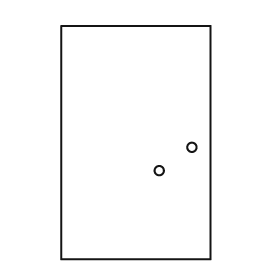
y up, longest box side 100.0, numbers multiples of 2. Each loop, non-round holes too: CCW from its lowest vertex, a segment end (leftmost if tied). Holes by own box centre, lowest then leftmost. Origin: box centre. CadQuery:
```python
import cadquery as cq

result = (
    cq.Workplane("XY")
    .moveTo(-32.0, -50.0)
    .lineTo(32.0, -50.0)
    .lineTo(32.0, 50.0)
    .lineTo(-32.0, 50.0)
    .close()
    .moveTo(10.0, -12.0)
    .circle(2.0)
    .moveTo(24.0, -2.0)
    .circle(2.0)
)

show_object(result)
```